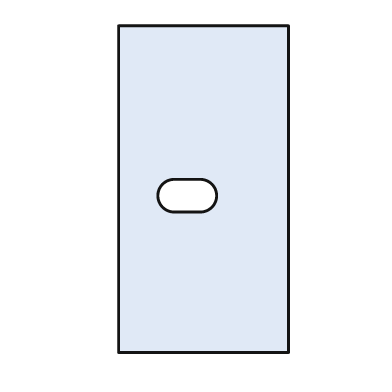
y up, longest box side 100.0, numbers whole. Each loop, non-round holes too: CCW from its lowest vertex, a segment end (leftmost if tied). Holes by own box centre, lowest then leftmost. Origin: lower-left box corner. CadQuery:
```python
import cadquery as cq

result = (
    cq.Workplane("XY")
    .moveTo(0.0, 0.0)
    .lineTo(52.0, 0.0)
    .lineTo(52.0, 100.0)
    .lineTo(0.0, 100.0)
    .close()
    .moveTo(17.0, 43.0)
    .lineTo(25.0, 43.0)
    .threePointArc((30.0, 48.0), (25.0, 53.0))
    .lineTo(17.0, 53.0)
    .threePointArc((12.0, 48.0), (17.0, 43.0))
    .close()
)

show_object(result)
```